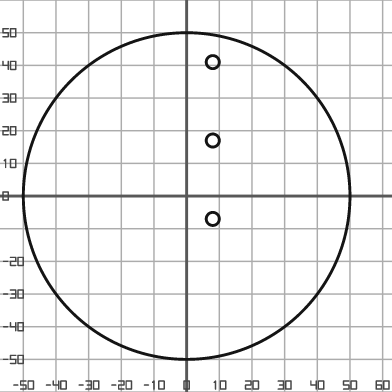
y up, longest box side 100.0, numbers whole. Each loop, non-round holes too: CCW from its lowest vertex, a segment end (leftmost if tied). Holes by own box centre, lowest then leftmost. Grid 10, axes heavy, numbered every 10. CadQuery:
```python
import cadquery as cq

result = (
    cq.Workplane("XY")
    .moveTo(0.0, 0.0)
    .circle(50.0)
    .moveTo(8.0, -7.0)
    .circle(2.0)
    .moveTo(8.0, 17.0)
    .circle(2.0)
    .moveTo(8.0, 41.0)
    .circle(2.0)
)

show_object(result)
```